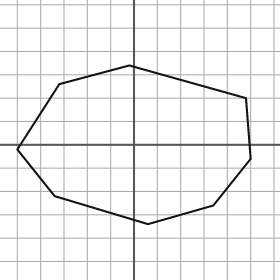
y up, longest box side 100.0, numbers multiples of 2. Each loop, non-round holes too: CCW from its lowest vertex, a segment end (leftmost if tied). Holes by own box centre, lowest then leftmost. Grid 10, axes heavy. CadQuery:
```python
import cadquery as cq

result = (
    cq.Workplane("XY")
    .moveTo(6.0, -34.0)
    .lineTo(34.0, -26.0)
    .lineTo(50.0, -6.0)
    .lineTo(48.0, 20.0)
    .lineTo(-2.0, 34.0)
    .lineTo(-32.0, 26.0)
    .lineTo(-50.0, -2.0)
    .lineTo(-34.0, -22.0)
    .close()
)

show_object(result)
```